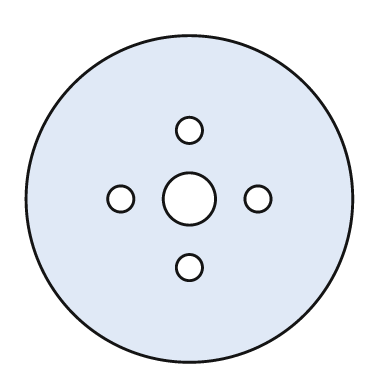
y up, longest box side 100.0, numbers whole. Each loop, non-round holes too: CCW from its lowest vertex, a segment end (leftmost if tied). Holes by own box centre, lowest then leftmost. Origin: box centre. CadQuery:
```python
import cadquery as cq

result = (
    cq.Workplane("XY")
    .moveTo(0.0, 0.0)
    .circle(50.0)
    .moveTo(0.0, -21.0)
    .circle(4.0)
    .moveTo(-21.0, 0.0)
    .circle(4.0)
    .moveTo(0.0, 0.0)
    .circle(8.0)
    .moveTo(21.0, 0.0)
    .circle(4.0)
    .moveTo(0.0, 21.0)
    .circle(4.0)
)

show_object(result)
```